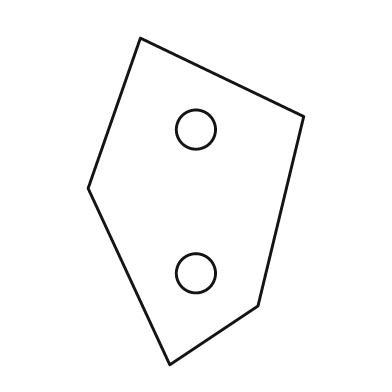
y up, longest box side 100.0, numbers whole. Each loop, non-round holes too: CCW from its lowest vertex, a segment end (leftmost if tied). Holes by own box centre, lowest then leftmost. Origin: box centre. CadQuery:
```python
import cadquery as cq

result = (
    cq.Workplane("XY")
    .moveTo(-8.0, -50.0)
    .lineTo(19.0, -32.0)
    .lineTo(33.0, 26.0)
    .lineTo(-17.0, 50.0)
    .lineTo(-33.0, 4.0)
    .close()
    .moveTo(0.0, -22.0)
    .circle(6.0)
    .moveTo(0.0, 22.0)
    .circle(6.0)
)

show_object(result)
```